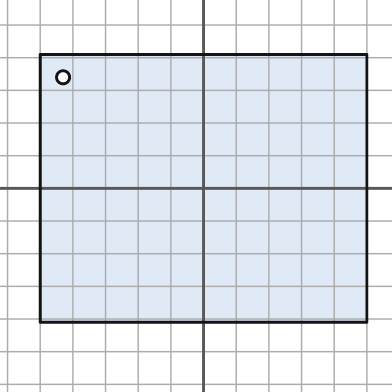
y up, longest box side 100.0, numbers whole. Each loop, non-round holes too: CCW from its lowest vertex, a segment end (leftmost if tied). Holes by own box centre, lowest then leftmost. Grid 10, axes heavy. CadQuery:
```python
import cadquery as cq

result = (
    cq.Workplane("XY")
    .moveTo(-50.0, -41.0)
    .lineTo(50.0, -41.0)
    .lineTo(50.0, 41.0)
    .lineTo(-50.0, 41.0)
    .close()
    .moveTo(-43.0, 34.0)
    .circle(2.0)
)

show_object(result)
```